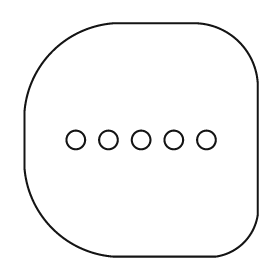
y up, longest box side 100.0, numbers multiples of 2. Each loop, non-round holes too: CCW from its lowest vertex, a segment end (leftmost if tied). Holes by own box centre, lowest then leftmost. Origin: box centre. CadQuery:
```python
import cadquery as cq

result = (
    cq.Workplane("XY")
    .moveTo(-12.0, -50.0)
    .lineTo(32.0, -50.0)
    .threePointArc((44.0, -44.0), (50.0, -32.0))
    .lineTo(50.0, 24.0)
    .threePointArc((42.0, 42.0), (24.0, 50.0))
    .lineTo(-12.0, 50.0)
    .threePointArc((-38.0, 38.0), (-50.0, 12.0))
    .lineTo(-50.0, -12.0)
    .threePointArc((-38.0, -38.0), (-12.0, -50.0))
    .close()
    .moveTo(-28.0, 0.0)
    .circle(4.0)
    .moveTo(-14.0, 0.0)
    .circle(4.0)
    .moveTo(0.0, 0.0)
    .circle(4.0)
    .moveTo(14.0, 0.0)
    .circle(4.0)
    .moveTo(28.0, 0.0)
    .circle(4.0)
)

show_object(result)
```